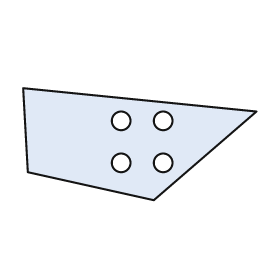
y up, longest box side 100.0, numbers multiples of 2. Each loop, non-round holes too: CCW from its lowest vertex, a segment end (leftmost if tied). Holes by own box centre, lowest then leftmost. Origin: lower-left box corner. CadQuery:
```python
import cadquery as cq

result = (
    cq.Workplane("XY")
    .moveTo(56.0, 0.0)
    .lineTo(100.0, 38.0)
    .lineTo(0.0, 48.0)
    .lineTo(2.0, 12.0)
    .close()
    .moveTo(42.0, 16.0)
    .circle(4.0)
    .moveTo(60.0, 16.0)
    .circle(4.0)
    .moveTo(42.0, 34.0)
    .circle(4.0)
    .moveTo(60.0, 34.0)
    .circle(4.0)
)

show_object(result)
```